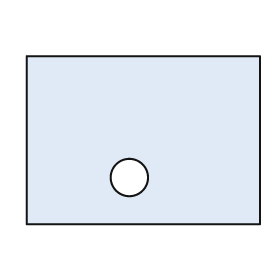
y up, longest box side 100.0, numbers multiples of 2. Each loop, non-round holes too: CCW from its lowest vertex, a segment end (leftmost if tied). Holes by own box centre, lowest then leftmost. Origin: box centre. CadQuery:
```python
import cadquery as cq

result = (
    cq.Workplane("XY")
    .moveTo(-50.0, -36.0)
    .lineTo(50.0, -36.0)
    .lineTo(50.0, 36.0)
    .lineTo(-50.0, 36.0)
    .close()
    .moveTo(-6.0, -16.0)
    .circle(8.0)
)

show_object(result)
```